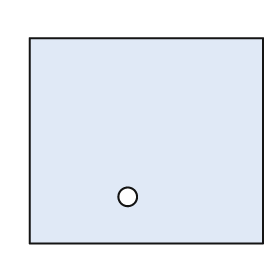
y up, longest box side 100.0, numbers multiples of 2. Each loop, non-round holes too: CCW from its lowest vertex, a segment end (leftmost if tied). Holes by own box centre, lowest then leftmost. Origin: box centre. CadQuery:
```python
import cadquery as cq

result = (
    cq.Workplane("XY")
    .moveTo(-50.0, -44.0)
    .lineTo(50.0, -44.0)
    .lineTo(50.0, 44.0)
    .lineTo(-50.0, 44.0)
    .close()
    .moveTo(-8.0, -24.0)
    .circle(4.0)
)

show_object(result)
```